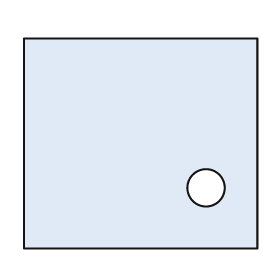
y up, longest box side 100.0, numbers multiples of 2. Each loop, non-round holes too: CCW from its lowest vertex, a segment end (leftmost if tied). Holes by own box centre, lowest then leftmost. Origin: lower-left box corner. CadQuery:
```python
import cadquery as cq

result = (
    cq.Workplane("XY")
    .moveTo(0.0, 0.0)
    .lineTo(100.0, 0.0)
    .lineTo(100.0, 90.0)
    .lineTo(0.0, 90.0)
    .close()
    .moveTo(78.0, 26.0)
    .circle(8.0)
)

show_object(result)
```